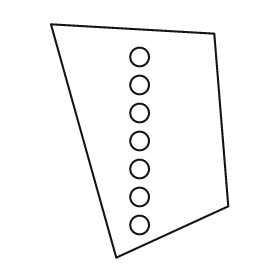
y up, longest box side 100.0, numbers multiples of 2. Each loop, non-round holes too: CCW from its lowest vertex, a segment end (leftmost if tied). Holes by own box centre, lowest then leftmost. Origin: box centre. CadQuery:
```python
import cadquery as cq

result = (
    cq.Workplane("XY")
    .moveTo(-10.0, -50.0)
    .lineTo(38.0, -28.0)
    .lineTo(32.0, 46.0)
    .lineTo(-38.0, 50.0)
    .close()
    .moveTo(0.0, -36.0)
    .circle(4.0)
    .moveTo(0.0, -24.0)
    .circle(4.0)
    .moveTo(0.0, -12.0)
    .circle(4.0)
    .moveTo(0.0, 0.0)
    .circle(4.0)
    .moveTo(0.0, 12.0)
    .circle(4.0)
    .moveTo(0.0, 24.0)
    .circle(4.0)
    .moveTo(0.0, 36.0)
    .circle(4.0)
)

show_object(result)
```